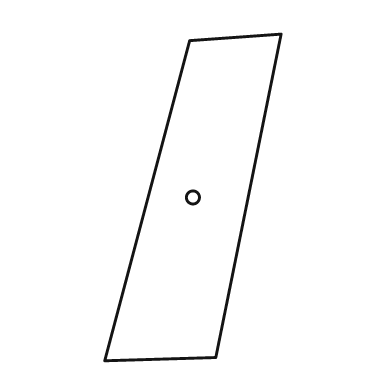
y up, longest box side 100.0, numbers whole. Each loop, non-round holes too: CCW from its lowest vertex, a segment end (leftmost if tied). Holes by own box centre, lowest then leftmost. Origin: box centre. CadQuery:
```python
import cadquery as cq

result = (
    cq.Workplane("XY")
    .moveTo(-27.0, -50.0)
    .lineTo(7.0, -49.0)
    .lineTo(27.0, 50.0)
    .lineTo(-1.0, 48.0)
    .close()
    .moveTo(0.0, 0.0)
    .circle(2.0)
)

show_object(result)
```